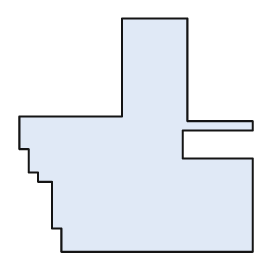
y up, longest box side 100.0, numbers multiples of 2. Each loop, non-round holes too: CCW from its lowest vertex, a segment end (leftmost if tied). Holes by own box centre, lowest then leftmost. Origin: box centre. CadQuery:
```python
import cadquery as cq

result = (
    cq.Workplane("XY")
    .moveTo(-32.0, -50.0)
    .lineTo(50.0, -50.0)
    .lineTo(50.0, -10.0)
    .lineTo(20.0, -10.0)
    .lineTo(20.0, 2.0)
    .lineTo(50.0, 2.0)
    .lineTo(50.0, 6.0)
    .lineTo(22.0, 6.0)
    .lineTo(22.0, 50.0)
    .lineTo(-6.0, 50.0)
    .lineTo(-6.0, 8.0)
    .lineTo(-50.0, 8.0)
    .lineTo(-50.0, -6.0)
    .lineTo(-46.0, -6.0)
    .lineTo(-46.0, -16.0)
    .lineTo(-42.0, -16.0)
    .lineTo(-42.0, -20.0)
    .lineTo(-36.0, -20.0)
    .lineTo(-36.0, -40.0)
    .lineTo(-32.0, -40.0)
    .close()
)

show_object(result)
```